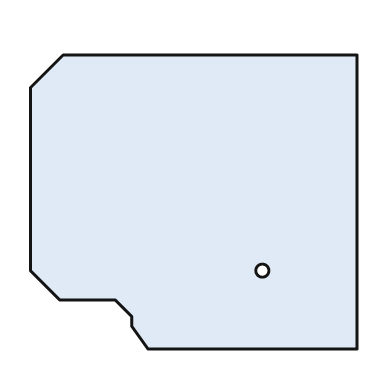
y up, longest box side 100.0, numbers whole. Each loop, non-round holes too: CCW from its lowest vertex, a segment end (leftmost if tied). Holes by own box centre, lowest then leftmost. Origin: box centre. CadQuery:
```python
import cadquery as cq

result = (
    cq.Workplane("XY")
    .moveTo(-14.0, -45.0)
    .lineTo(50.0, -45.0)
    .lineTo(50.0, 45.0)
    .lineTo(-40.0, 45.0)
    .lineTo(-50.0, 35.0)
    .lineTo(-50.0, -21.0)
    .lineTo(-41.0, -30.0)
    .lineTo(-24.0, -30.0)
    .lineTo(-19.0, -35.0)
    .lineTo(-19.0, -38.0)
    .close()
    .moveTo(21.0, -21.0)
    .circle(2.0)
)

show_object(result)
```